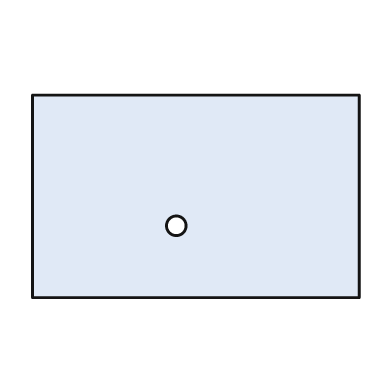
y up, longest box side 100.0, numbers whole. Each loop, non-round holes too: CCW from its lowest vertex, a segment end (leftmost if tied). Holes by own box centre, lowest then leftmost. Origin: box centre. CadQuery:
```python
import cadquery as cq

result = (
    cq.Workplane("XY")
    .moveTo(-50.0, -31.0)
    .lineTo(50.0, -31.0)
    .lineTo(50.0, 31.0)
    .lineTo(-50.0, 31.0)
    .close()
    .moveTo(-6.0, -9.0)
    .circle(3.0)
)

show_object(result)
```